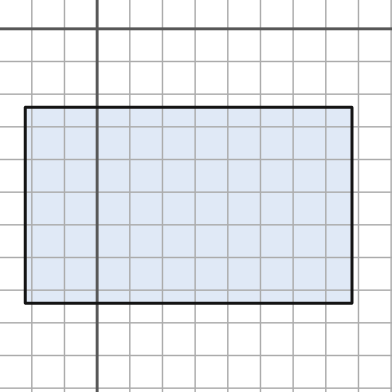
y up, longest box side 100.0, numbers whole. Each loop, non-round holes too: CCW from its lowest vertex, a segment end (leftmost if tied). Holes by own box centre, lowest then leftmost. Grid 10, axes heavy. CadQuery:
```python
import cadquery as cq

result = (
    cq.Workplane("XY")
    .moveTo(-22.0, -84.0)
    .lineTo(78.0, -84.0)
    .lineTo(78.0, -24.0)
    .lineTo(-22.0, -24.0)
    .close()
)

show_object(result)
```